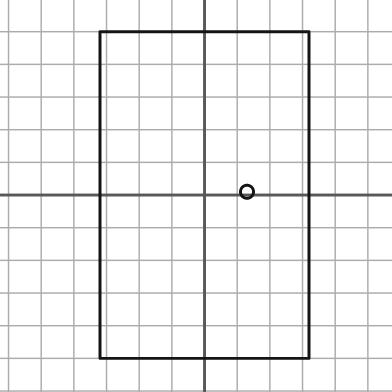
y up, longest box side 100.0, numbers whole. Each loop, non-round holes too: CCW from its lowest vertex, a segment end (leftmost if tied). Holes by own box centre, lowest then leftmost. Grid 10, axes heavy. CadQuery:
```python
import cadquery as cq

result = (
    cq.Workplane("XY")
    .moveTo(-32.0, -50.0)
    .lineTo(32.0, -50.0)
    .lineTo(32.0, 50.0)
    .lineTo(-32.0, 50.0)
    .close()
    .moveTo(13.0, 1.0)
    .circle(2.0)
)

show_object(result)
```